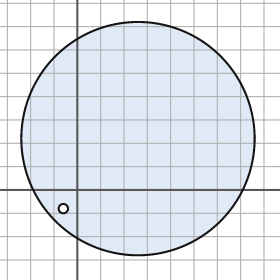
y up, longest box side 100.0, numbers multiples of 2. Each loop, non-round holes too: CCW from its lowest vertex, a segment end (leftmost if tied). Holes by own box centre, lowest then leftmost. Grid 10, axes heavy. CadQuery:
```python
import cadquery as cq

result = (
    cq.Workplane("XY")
    .moveTo(26.0, 22.0)
    .circle(50.0)
    .moveTo(-6.0, -8.0)
    .circle(2.0)
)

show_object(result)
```